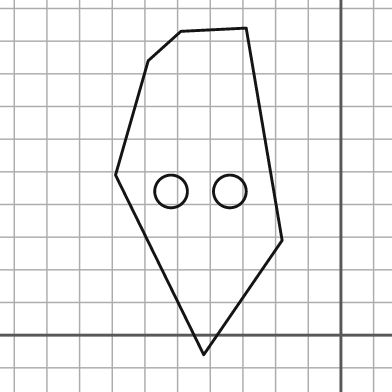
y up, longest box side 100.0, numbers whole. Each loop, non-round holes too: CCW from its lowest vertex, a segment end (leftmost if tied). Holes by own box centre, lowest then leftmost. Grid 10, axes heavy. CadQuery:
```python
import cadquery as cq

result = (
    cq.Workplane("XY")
    .moveTo(-42.0, -6.0)
    .lineTo(-18.0, 29.0)
    .lineTo(-29.0, 94.0)
    .lineTo(-49.0, 93.0)
    .lineTo(-59.0, 84.0)
    .lineTo(-69.0, 49.0)
    .close()
    .moveTo(-52.0, 44.0)
    .circle(5.0)
    .moveTo(-34.0, 44.0)
    .circle(5.0)
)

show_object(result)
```